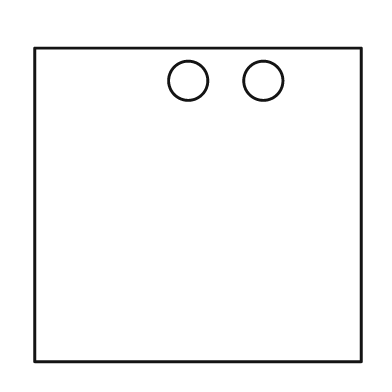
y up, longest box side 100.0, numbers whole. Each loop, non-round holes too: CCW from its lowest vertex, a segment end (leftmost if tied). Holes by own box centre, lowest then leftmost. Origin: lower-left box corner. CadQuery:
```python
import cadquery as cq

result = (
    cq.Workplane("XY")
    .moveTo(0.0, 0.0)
    .lineTo(100.0, 0.0)
    .lineTo(100.0, 96.0)
    .lineTo(0.0, 96.0)
    .close()
    .moveTo(47.0, 86.0)
    .circle(6.0)
    .moveTo(70.0, 86.0)
    .circle(6.0)
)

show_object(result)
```